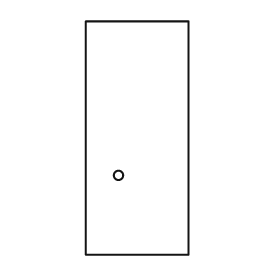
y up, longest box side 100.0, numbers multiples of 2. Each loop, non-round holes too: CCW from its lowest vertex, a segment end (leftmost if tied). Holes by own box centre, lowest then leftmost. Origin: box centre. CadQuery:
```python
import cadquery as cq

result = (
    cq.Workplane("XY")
    .moveTo(-22.0, -50.0)
    .lineTo(22.0, -50.0)
    .lineTo(22.0, 50.0)
    .lineTo(-22.0, 50.0)
    .close()
    .moveTo(-8.0, -16.0)
    .circle(2.0)
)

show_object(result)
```